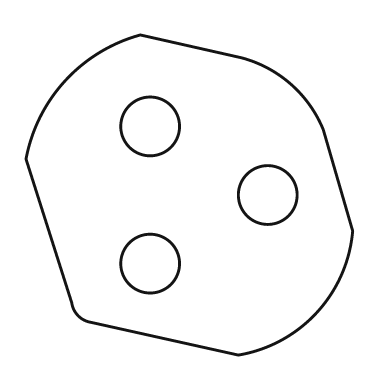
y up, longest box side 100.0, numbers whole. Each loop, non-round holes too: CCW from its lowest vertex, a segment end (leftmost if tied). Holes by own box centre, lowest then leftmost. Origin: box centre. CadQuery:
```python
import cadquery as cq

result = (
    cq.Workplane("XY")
    .moveTo(15.0, -49.0)
    .threePointArc((39.0, -36.0), (50.0, -11.0))
    .lineTo(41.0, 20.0)
    .threePointArc((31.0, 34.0), (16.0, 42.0))
    .lineTo(-15.0, 49.0)
    .threePointArc((-38.0, 35.0), (-50.0, 11.0))
    .lineTo(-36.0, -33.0)
    .threePointArc((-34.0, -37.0), (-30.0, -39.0))
    .close()
    .moveTo(-12.0, -21.0)
    .circle(9.0)
    .moveTo(24.0, 0.0)
    .circle(9.0)
    .moveTo(-12.0, 21.0)
    .circle(9.0)
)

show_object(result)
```